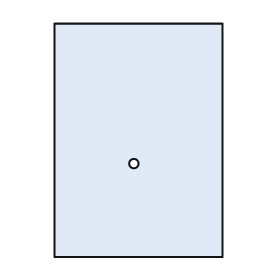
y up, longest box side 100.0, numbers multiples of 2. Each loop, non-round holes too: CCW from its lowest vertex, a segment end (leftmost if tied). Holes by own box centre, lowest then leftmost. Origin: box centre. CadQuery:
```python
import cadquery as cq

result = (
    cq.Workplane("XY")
    .moveTo(-36.0, -50.0)
    .lineTo(36.0, -50.0)
    .lineTo(36.0, 50.0)
    .lineTo(-36.0, 50.0)
    .close()
    .moveTo(-2.0, -10.0)
    .circle(2.0)
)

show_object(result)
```